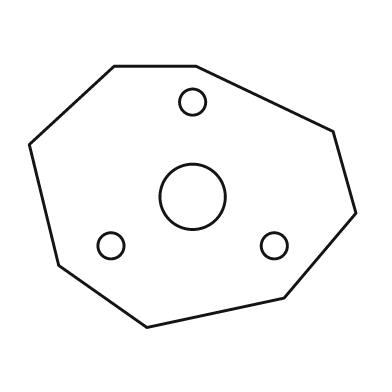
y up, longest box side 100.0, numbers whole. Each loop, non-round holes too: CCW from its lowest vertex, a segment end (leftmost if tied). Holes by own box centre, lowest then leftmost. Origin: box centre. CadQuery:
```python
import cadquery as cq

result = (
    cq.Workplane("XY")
    .moveTo(-14.0, -40.0)
    .lineTo(28.0, -31.0)
    .lineTo(50.0, -5.0)
    .lineTo(43.0, 20.0)
    .lineTo(1.0, 40.0)
    .lineTo(-24.0, 40.0)
    .lineTo(-50.0, 16.0)
    .lineTo(-41.0, -21.0)
    .close()
    .moveTo(-25.0, -15.0)
    .circle(4.0)
    .moveTo(25.0, -15.0)
    .circle(4.0)
    .moveTo(0.0, 0.0)
    .circle(10.0)
    .moveTo(0.0, 29.0)
    .circle(4.0)
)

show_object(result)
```